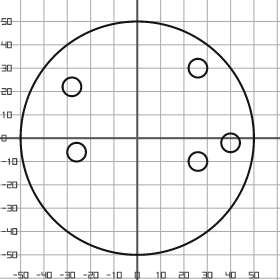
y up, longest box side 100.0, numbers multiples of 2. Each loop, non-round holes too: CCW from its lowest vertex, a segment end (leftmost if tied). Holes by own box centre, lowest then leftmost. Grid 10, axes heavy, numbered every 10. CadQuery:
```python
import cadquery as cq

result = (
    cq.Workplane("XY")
    .moveTo(0.0, 0.0)
    .circle(50.0)
    .moveTo(26.0, -10.0)
    .circle(4.0)
    .moveTo(-26.0, -6.0)
    .circle(4.0)
    .moveTo(40.0, -2.0)
    .circle(4.0)
    .moveTo(-28.0, 22.0)
    .circle(4.0)
    .moveTo(26.0, 30.0)
    .circle(4.0)
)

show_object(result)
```